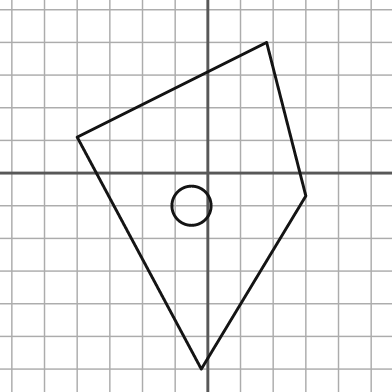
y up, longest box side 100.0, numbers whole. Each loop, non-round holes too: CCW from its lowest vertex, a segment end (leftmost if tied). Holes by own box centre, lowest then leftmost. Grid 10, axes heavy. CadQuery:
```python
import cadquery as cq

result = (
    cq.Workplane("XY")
    .moveTo(-2.0, -60.0)
    .lineTo(30.0, -7.0)
    .lineTo(18.0, 40.0)
    .lineTo(-40.0, 11.0)
    .close()
    .moveTo(-5.0, -10.0)
    .circle(6.0)
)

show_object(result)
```